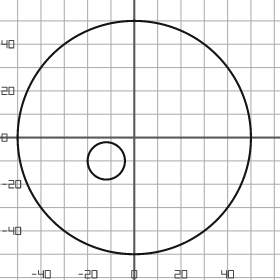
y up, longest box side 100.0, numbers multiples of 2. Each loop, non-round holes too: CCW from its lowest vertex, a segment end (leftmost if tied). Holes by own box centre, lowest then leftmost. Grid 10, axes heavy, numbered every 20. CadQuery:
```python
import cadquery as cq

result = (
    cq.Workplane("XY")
    .moveTo(0.0, 0.0)
    .circle(50.0)
    .moveTo(-12.0, -10.0)
    .circle(8.0)
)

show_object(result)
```